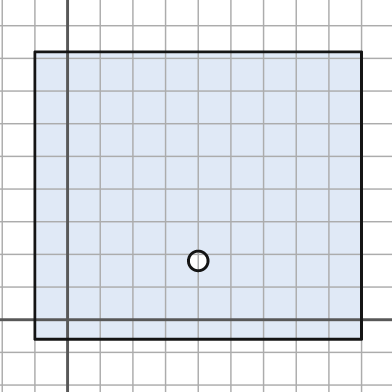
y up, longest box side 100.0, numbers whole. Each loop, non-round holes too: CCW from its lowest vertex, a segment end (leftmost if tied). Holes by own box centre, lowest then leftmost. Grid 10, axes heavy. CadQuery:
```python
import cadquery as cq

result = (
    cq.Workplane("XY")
    .moveTo(-10.0, -6.0)
    .lineTo(90.0, -6.0)
    .lineTo(90.0, 82.0)
    .lineTo(-10.0, 82.0)
    .close()
    .moveTo(40.0, 18.0)
    .circle(3.0)
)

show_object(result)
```